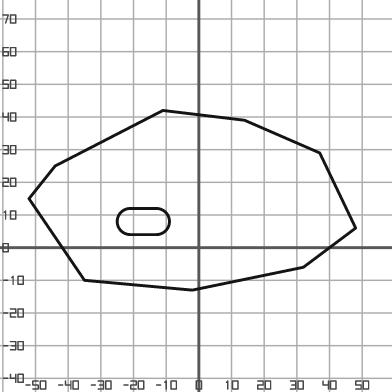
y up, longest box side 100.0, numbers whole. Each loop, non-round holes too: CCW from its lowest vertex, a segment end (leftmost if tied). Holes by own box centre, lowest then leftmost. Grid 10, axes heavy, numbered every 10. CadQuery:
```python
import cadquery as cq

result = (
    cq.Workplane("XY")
    .moveTo(-2.0, -13.0)
    .lineTo(32.0, -6.0)
    .lineTo(48.0, 6.0)
    .lineTo(37.0, 29.0)
    .lineTo(14.0, 39.0)
    .lineTo(-11.0, 42.0)
    .lineTo(-44.0, 25.0)
    .lineTo(-52.0, 15.0)
    .lineTo(-35.0, -10.0)
    .close()
    .moveTo(-21.0, 4.0)
    .lineTo(-13.0, 4.0)
    .threePointArc((-9.0, 8.0), (-13.0, 12.0))
    .lineTo(-21.0, 12.0)
    .threePointArc((-25.0, 8.0), (-21.0, 4.0))
    .close()
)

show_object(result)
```